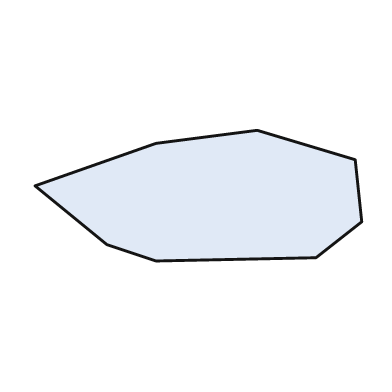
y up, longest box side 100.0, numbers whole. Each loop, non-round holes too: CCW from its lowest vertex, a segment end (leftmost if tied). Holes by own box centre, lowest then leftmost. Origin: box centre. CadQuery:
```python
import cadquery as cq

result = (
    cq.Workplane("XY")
    .moveTo(-13.0, -20.0)
    .lineTo(36.0, -19.0)
    .lineTo(50.0, -8.0)
    .lineTo(48.0, 11.0)
    .lineTo(18.0, 20.0)
    .lineTo(-13.0, 16.0)
    .lineTo(-50.0, 3.0)
    .lineTo(-28.0, -15.0)
    .close()
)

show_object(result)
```